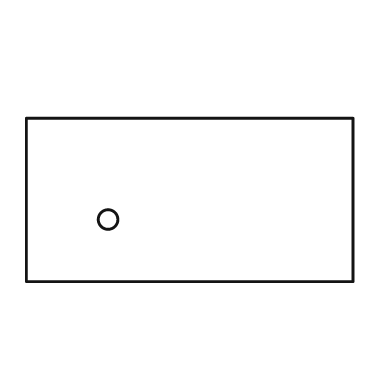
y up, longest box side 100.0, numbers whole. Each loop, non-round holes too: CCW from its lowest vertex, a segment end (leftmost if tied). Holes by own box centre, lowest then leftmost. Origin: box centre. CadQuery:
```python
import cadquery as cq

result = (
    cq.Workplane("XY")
    .moveTo(-50.0, -25.0)
    .lineTo(50.0, -25.0)
    .lineTo(50.0, 25.0)
    .lineTo(-50.0, 25.0)
    .close()
    .moveTo(-25.0, -6.0)
    .circle(3.0)
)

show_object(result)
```